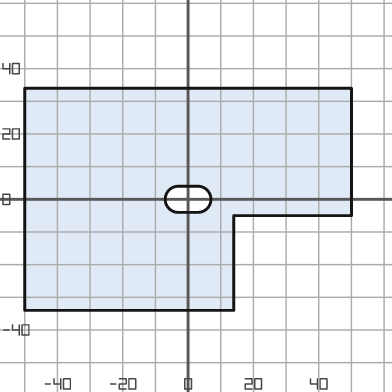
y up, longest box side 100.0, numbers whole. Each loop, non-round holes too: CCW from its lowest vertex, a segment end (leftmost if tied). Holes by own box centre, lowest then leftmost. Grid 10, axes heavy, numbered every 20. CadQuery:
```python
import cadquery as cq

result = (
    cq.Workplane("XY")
    .moveTo(-50.0, -34.0)
    .lineTo(14.0, -34.0)
    .lineTo(14.0, -5.0)
    .lineTo(50.0, -5.0)
    .lineTo(50.0, 34.0)
    .lineTo(-50.0, 34.0)
    .close()
    .moveTo(-3.0, -4.0)
    .lineTo(3.0, -4.0)
    .threePointArc((7.0, 0.0), (3.0, 4.0))
    .lineTo(-3.0, 4.0)
    .threePointArc((-7.0, 0.0), (-3.0, -4.0))
    .close()
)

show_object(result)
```